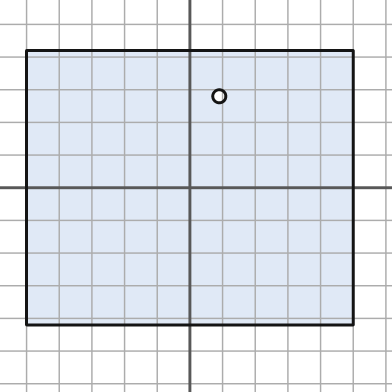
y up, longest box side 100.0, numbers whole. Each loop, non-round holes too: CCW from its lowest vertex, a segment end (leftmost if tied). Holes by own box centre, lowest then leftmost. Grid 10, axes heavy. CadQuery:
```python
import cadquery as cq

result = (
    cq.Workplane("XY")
    .moveTo(-50.0, -42.0)
    .lineTo(50.0, -42.0)
    .lineTo(50.0, 42.0)
    .lineTo(-50.0, 42.0)
    .close()
    .moveTo(9.0, 28.0)
    .circle(2.0)
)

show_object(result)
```